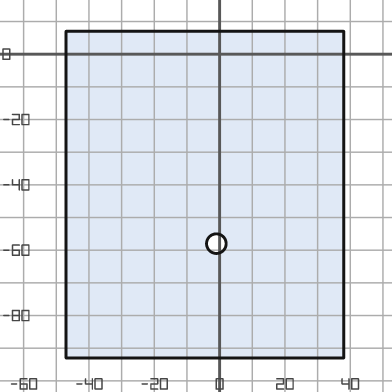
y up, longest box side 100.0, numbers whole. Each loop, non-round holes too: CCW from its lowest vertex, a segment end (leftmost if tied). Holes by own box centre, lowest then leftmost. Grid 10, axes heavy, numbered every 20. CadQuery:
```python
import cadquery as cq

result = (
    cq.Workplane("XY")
    .moveTo(-47.0, -93.0)
    .lineTo(38.0, -93.0)
    .lineTo(38.0, 7.0)
    .lineTo(-47.0, 7.0)
    .close()
    .moveTo(-1.0, -58.0)
    .circle(3.0)
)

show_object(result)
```